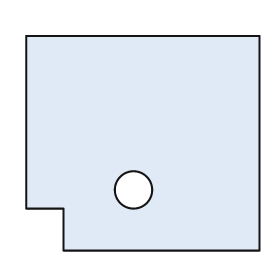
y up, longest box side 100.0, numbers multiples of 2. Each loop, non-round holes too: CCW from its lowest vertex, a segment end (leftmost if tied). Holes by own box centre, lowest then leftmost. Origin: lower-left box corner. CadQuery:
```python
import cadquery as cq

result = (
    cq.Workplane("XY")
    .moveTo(16.0, 0.0)
    .lineTo(100.0, 0.0)
    .lineTo(100.0, 92.0)
    .lineTo(0.0, 92.0)
    .lineTo(0.0, 18.0)
    .lineTo(16.0, 18.0)
    .close()
    .moveTo(46.0, 26.0)
    .circle(8.0)
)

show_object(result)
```